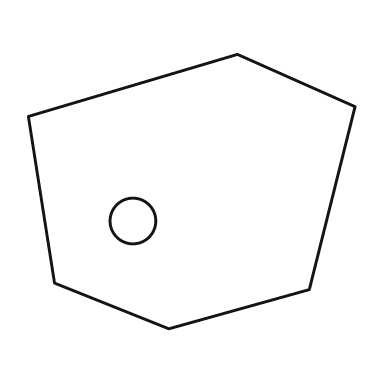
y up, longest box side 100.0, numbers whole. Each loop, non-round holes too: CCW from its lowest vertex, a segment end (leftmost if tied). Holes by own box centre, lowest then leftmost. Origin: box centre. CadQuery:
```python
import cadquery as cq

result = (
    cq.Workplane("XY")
    .moveTo(-7.0, -42.0)
    .lineTo(36.0, -30.0)
    .lineTo(50.0, 26.0)
    .lineTo(14.0, 42.0)
    .lineTo(-50.0, 23.0)
    .lineTo(-42.0, -28.0)
    .close()
    .moveTo(-18.0, -9.0)
    .circle(7.0)
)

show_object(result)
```